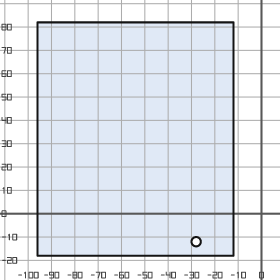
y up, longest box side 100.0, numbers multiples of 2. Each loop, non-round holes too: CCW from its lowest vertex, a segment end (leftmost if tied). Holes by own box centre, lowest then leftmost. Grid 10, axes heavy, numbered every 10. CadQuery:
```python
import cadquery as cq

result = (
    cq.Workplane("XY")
    .moveTo(-96.0, -18.0)
    .lineTo(-12.0, -18.0)
    .lineTo(-12.0, 82.0)
    .lineTo(-96.0, 82.0)
    .close()
    .moveTo(-28.0, -12.0)
    .circle(2.0)
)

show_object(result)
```